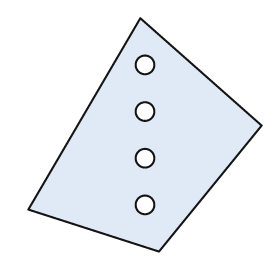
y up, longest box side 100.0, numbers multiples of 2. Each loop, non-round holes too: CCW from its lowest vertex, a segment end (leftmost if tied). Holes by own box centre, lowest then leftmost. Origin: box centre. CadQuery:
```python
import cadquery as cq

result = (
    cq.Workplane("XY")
    .moveTo(6.0, -50.0)
    .lineTo(50.0, 4.0)
    .lineTo(-2.0, 50.0)
    .lineTo(-50.0, -32.0)
    .close()
    .moveTo(0.0, -30.0)
    .circle(4.0)
    .moveTo(0.0, -10.0)
    .circle(4.0)
    .moveTo(0.0, 10.0)
    .circle(4.0)
    .moveTo(0.0, 30.0)
    .circle(4.0)
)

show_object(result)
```